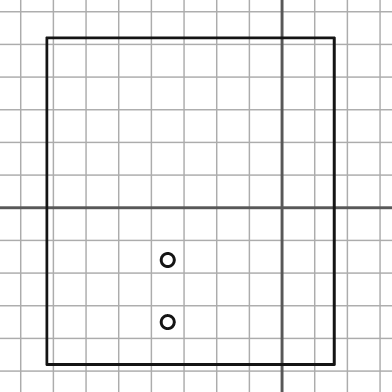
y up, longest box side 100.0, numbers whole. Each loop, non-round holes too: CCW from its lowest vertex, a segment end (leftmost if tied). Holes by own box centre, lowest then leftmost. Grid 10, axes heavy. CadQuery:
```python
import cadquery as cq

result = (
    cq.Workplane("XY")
    .moveTo(-72.0, -48.0)
    .lineTo(16.0, -48.0)
    .lineTo(16.0, 52.0)
    .lineTo(-72.0, 52.0)
    .close()
    .moveTo(-35.0, -35.0)
    .circle(2.0)
    .moveTo(-35.0, -16.0)
    .circle(2.0)
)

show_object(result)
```